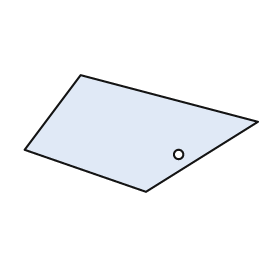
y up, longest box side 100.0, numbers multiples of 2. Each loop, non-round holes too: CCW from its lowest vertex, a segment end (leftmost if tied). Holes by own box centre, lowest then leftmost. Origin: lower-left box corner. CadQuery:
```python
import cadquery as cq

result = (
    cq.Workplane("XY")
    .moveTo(52.0, 0.0)
    .lineTo(100.0, 30.0)
    .lineTo(24.0, 50.0)
    .lineTo(0.0, 18.0)
    .close()
    .moveTo(66.0, 16.0)
    .circle(2.0)
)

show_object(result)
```